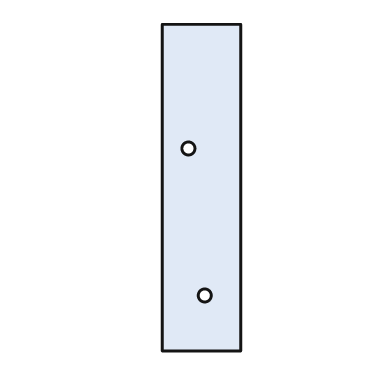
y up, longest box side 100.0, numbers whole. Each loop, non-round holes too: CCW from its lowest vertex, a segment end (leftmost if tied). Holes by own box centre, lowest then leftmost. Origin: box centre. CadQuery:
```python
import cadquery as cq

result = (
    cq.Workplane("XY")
    .moveTo(-12.0, -50.0)
    .lineTo(12.0, -50.0)
    .lineTo(12.0, 50.0)
    .lineTo(-12.0, 50.0)
    .close()
    .moveTo(1.0, -33.0)
    .circle(2.0)
    .moveTo(-4.0, 12.0)
    .circle(2.0)
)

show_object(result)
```